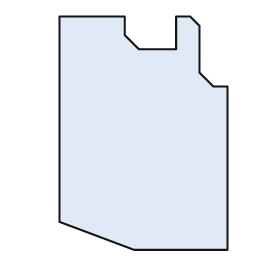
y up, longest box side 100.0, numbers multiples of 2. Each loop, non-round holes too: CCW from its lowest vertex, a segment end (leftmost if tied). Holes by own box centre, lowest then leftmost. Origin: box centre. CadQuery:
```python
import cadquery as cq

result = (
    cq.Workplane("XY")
    .moveTo(-4.0, -50.0)
    .lineTo(36.0, -50.0)
    .lineTo(36.0, 20.0)
    .lineTo(30.0, 20.0)
    .lineTo(24.0, 26.0)
    .lineTo(24.0, 46.0)
    .lineTo(20.0, 50.0)
    .lineTo(14.0, 50.0)
    .lineTo(14.0, 36.0)
    .lineTo(-2.0, 36.0)
    .lineTo(-8.0, 42.0)
    .lineTo(-8.0, 50.0)
    .lineTo(-36.0, 50.0)
    .lineTo(-36.0, -38.0)
    .close()
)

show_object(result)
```